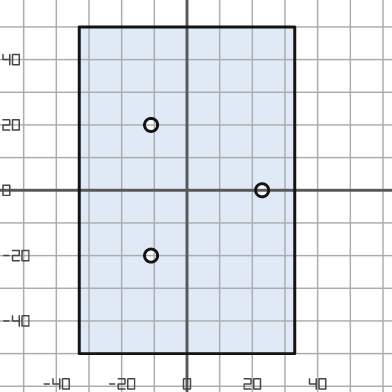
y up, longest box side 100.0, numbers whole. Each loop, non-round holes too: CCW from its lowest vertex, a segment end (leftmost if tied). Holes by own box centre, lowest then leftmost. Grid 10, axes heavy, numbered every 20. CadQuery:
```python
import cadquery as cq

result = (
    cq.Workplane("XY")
    .moveTo(-33.0, -50.0)
    .lineTo(33.0, -50.0)
    .lineTo(33.0, 50.0)
    .lineTo(-33.0, 50.0)
    .close()
    .moveTo(-11.0, -20.0)
    .circle(2.0)
    .moveTo(23.0, 0.0)
    .circle(2.0)
    .moveTo(-11.0, 20.0)
    .circle(2.0)
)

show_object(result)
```